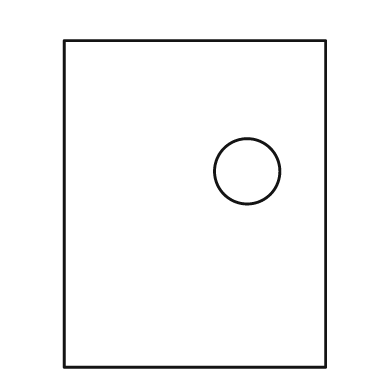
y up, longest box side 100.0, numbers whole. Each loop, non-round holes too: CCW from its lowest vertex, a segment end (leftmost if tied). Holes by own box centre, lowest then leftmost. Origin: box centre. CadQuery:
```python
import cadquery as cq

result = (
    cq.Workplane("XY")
    .moveTo(-40.0, -50.0)
    .lineTo(40.0, -50.0)
    .lineTo(40.0, 50.0)
    .lineTo(-40.0, 50.0)
    .close()
    .moveTo(16.0, 10.0)
    .circle(10.0)
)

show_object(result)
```